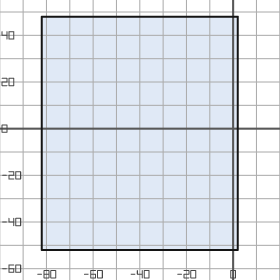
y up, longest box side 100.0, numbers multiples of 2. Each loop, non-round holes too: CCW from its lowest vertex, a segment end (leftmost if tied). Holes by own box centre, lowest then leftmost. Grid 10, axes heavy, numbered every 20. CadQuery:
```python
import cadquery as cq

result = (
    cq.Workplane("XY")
    .moveTo(-82.0, -52.0)
    .lineTo(2.0, -52.0)
    .lineTo(2.0, 48.0)
    .lineTo(-82.0, 48.0)
    .close()
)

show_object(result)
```